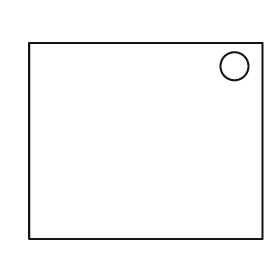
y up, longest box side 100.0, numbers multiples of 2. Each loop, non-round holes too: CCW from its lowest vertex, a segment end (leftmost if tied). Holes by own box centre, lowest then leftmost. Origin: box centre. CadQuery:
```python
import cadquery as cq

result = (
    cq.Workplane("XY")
    .moveTo(-50.0, -42.0)
    .lineTo(50.0, -42.0)
    .lineTo(50.0, 42.0)
    .lineTo(-50.0, 42.0)
    .close()
    .moveTo(38.0, 32.0)
    .circle(6.0)
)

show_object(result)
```